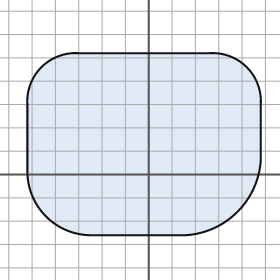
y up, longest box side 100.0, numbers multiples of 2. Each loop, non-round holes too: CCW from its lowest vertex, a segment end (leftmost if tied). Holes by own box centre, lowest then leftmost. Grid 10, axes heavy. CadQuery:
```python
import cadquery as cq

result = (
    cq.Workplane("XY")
    .moveTo(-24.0, -26.0)
    .lineTo(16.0, -26.0)
    .threePointArc((38.0, -16.0), (48.0, 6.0))
    .lineTo(48.0, 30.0)
    .threePointArc((42.0, 46.0), (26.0, 52.0))
    .lineTo(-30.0, 52.0)
    .threePointArc((-46.0, 46.0), (-52.0, 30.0))
    .lineTo(-52.0, 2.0)
    .threePointArc((-44.0, -18.0), (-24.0, -26.0))
    .close()
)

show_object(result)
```